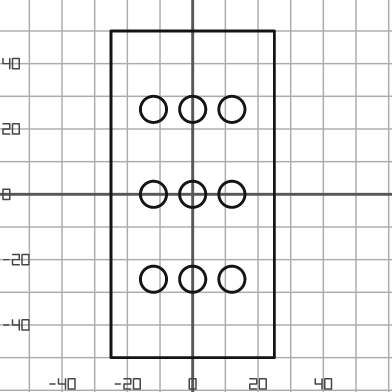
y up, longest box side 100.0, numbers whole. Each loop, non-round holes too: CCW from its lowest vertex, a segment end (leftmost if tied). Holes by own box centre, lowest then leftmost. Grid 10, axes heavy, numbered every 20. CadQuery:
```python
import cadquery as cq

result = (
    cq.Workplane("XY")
    .moveTo(-25.0, -50.0)
    .lineTo(25.0, -50.0)
    .lineTo(25.0, 50.0)
    .lineTo(-25.0, 50.0)
    .close()
    .moveTo(-12.0, -26.0)
    .circle(4.0)
    .moveTo(0.0, -26.0)
    .circle(4.0)
    .moveTo(12.0, -26.0)
    .circle(4.0)
    .moveTo(-12.0, 0.0)
    .circle(4.0)
    .moveTo(0.0, 0.0)
    .circle(4.0)
    .moveTo(12.0, 0.0)
    .circle(4.0)
    .moveTo(-12.0, 26.0)
    .circle(4.0)
    .moveTo(0.0, 26.0)
    .circle(4.0)
    .moveTo(12.0, 26.0)
    .circle(4.0)
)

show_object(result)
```